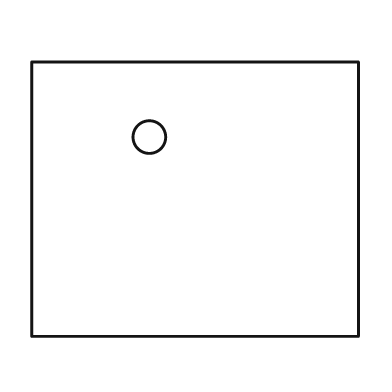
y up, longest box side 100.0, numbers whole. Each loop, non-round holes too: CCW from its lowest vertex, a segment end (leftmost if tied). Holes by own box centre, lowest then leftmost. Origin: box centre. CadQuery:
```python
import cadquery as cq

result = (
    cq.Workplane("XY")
    .moveTo(-50.0, -42.0)
    .lineTo(50.0, -42.0)
    .lineTo(50.0, 42.0)
    .lineTo(-50.0, 42.0)
    .close()
    .moveTo(-14.0, 19.0)
    .circle(5.0)
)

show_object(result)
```